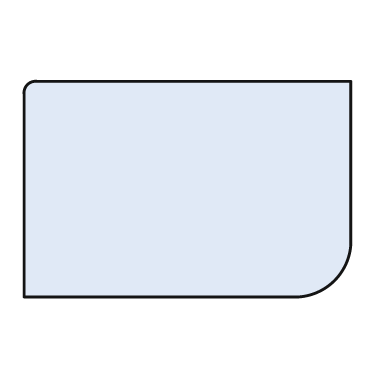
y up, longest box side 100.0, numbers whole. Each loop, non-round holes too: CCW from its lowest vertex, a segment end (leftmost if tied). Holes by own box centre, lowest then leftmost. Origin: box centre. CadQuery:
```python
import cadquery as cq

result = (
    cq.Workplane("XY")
    .moveTo(-50.0, -33.0)
    .lineTo(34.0, -33.0)
    .threePointArc((45.0, -28.0), (50.0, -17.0))
    .lineTo(50.0, 33.0)
    .lineTo(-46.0, 33.0)
    .threePointArc((-49.0, 32.0), (-50.0, 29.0))
    .close()
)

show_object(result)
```